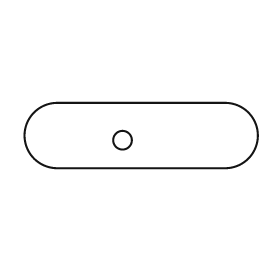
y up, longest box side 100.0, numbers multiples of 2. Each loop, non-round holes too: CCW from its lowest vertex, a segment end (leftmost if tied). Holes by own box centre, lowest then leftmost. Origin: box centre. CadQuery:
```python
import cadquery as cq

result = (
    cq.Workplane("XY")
    .moveTo(-36.0, -14.0)
    .lineTo(36.0, -14.0)
    .threePointArc((50.0, 0.0), (36.0, 14.0))
    .lineTo(-36.0, 14.0)
    .threePointArc((-50.0, 0.0), (-36.0, -14.0))
    .close()
    .moveTo(-8.0, -2.0)
    .circle(4.0)
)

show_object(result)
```